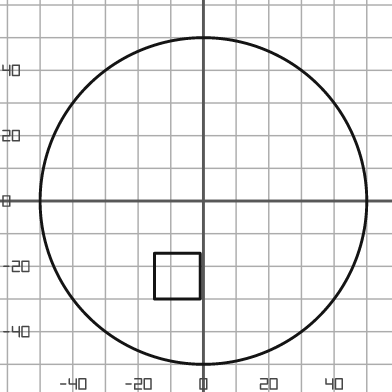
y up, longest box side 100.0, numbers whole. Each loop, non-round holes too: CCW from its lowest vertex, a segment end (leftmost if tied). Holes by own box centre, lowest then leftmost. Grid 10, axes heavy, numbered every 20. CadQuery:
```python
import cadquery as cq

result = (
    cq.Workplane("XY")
    .moveTo(0.0, 0.0)
    .circle(50.0)
    .moveTo(-15.0, -30.0)
    .lineTo(-1.0, -30.0)
    .lineTo(-1.0, -16.0)
    .lineTo(-15.0, -16.0)
    .close()
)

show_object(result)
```